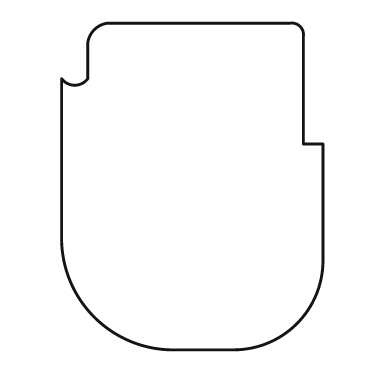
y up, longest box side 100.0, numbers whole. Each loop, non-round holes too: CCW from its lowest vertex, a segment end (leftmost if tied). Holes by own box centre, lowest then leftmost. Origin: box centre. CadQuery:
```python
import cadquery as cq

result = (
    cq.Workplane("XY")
    .moveTo(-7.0, -50.0)
    .lineTo(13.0, -50.0)
    .threePointArc((32.0, -42.0), (40.0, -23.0))
    .lineTo(40.0, 13.0)
    .lineTo(34.0, 13.0)
    .lineTo(34.0, 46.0)
    .threePointArc((33.0, 49.0), (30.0, 50.0))
    .lineTo(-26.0, 50.0)
    .threePointArc((-30.0, 48.0), (-32.0, 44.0))
    .lineTo(-32.0, 33.0)
    .threePointArc((-36.0, 31.0), (-40.0, 33.0))
    .lineTo(-40.0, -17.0)
    .threePointArc((-30.0, -40.0), (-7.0, -50.0))
    .close()
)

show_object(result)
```